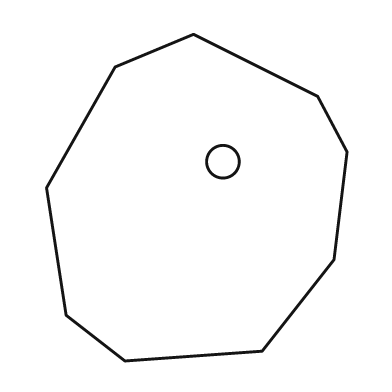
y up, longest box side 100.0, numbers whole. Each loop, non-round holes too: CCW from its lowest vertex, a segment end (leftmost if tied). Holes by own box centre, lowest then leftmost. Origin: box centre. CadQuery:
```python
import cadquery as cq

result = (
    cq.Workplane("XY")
    .moveTo(-22.0, -50.0)
    .lineTo(20.0, -47.0)
    .lineTo(42.0, -19.0)
    .lineTo(46.0, 14.0)
    .lineTo(37.0, 31.0)
    .lineTo(-1.0, 50.0)
    .lineTo(-25.0, 40.0)
    .lineTo(-46.0, 3.0)
    .lineTo(-40.0, -36.0)
    .close()
    .moveTo(8.0, 11.0)
    .circle(5.0)
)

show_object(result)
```